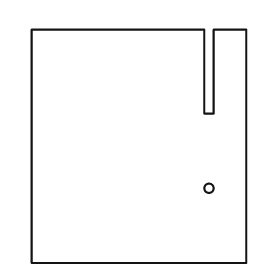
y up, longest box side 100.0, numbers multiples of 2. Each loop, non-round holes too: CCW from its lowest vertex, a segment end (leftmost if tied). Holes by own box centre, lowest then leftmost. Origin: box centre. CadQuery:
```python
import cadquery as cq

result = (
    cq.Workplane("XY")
    .moveTo(-46.0, -50.0)
    .lineTo(46.0, -50.0)
    .lineTo(46.0, 50.0)
    .lineTo(32.0, 50.0)
    .lineTo(32.0, 14.0)
    .lineTo(28.0, 14.0)
    .lineTo(28.0, 50.0)
    .lineTo(-46.0, 50.0)
    .close()
    .moveTo(30.0, -18.0)
    .circle(2.0)
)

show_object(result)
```